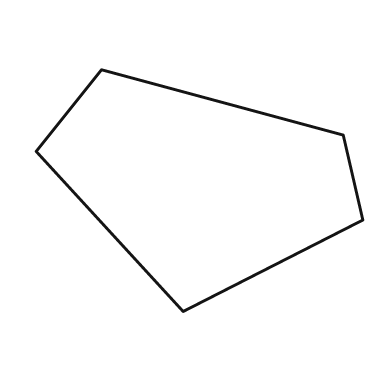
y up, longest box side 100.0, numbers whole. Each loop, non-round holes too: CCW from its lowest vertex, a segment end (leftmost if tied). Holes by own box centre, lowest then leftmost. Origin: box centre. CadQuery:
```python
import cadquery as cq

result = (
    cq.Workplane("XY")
    .moveTo(-5.0, -37.0)
    .lineTo(50.0, -9.0)
    .lineTo(44.0, 17.0)
    .lineTo(-30.0, 37.0)
    .lineTo(-50.0, 12.0)
    .close()
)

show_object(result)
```